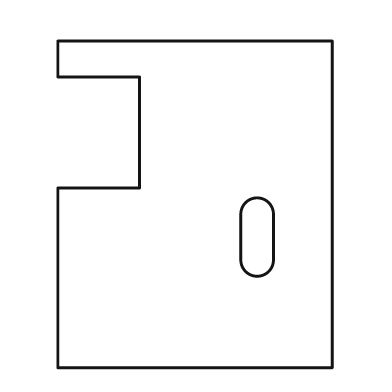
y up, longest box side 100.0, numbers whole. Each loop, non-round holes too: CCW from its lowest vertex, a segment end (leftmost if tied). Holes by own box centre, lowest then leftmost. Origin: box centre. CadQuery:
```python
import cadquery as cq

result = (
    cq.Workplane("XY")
    .moveTo(-42.0, -50.0)
    .lineTo(42.0, -50.0)
    .lineTo(42.0, 50.0)
    .lineTo(-42.0, 50.0)
    .lineTo(-42.0, 39.0)
    .lineTo(-17.0, 39.0)
    .lineTo(-17.0, 5.0)
    .lineTo(-42.0, 5.0)
    .close()
    .moveTo(14.0, -17.0)
    .threePointArc((19.0, -22.0), (24.0, -17.0))
    .lineTo(24.0, -3.0)
    .threePointArc((19.0, 2.0), (14.0, -3.0))
    .close()
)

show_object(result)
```